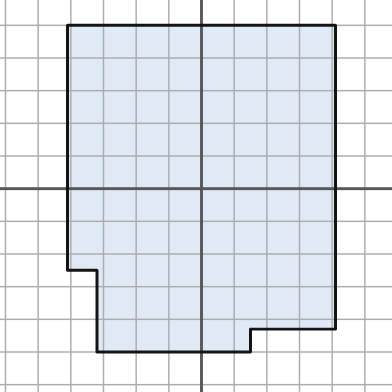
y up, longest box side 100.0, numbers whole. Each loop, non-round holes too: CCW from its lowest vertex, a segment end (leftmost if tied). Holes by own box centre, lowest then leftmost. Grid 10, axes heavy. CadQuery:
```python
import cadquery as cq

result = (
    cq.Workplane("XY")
    .moveTo(-32.0, -50.0)
    .lineTo(15.0, -50.0)
    .lineTo(15.0, -43.0)
    .lineTo(41.0, -43.0)
    .lineTo(41.0, 50.0)
    .lineTo(-41.0, 50.0)
    .lineTo(-41.0, -25.0)
    .lineTo(-32.0, -25.0)
    .close()
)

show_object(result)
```